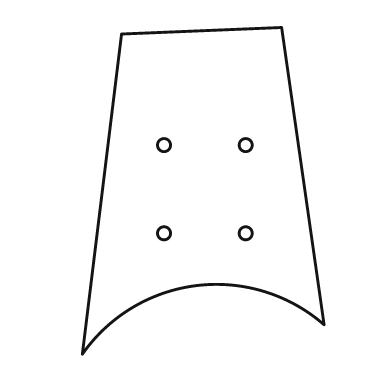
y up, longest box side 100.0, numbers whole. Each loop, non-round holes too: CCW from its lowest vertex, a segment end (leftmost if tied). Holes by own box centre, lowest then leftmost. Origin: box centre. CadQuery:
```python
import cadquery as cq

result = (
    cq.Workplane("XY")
    .moveTo(-37.0, -50.0)
    .threePointArc((-2.0, -29.0), (37.0, -41.0))
    .lineTo(24.0, 50.0)
    .lineTo(-25.0, 48.0)
    .close()
    .moveTo(-12.0, -13.0)
    .circle(2.0)
    .moveTo(13.0, -13.0)
    .circle(2.0)
    .moveTo(-12.0, 14.0)
    .circle(2.0)
    .moveTo(13.0, 14.0)
    .circle(2.0)
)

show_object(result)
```